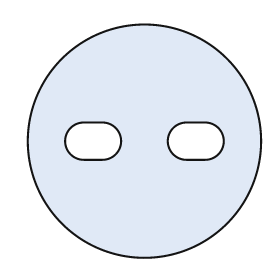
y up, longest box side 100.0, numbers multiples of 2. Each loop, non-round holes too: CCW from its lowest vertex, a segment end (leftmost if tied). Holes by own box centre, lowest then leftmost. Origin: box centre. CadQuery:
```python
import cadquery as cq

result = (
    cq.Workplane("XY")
    .moveTo(0.0, 0.0)
    .circle(50.0)
    .moveTo(-26.0, -8.0)
    .lineTo(-18.0, -8.0)
    .threePointArc((-10.0, 0.0), (-18.0, 8.0))
    .lineTo(-26.0, 8.0)
    .threePointArc((-34.0, 0.0), (-26.0, -8.0))
    .close()
    .moveTo(18.0, -8.0)
    .lineTo(26.0, -8.0)
    .threePointArc((34.0, 0.0), (26.0, 8.0))
    .lineTo(18.0, 8.0)
    .threePointArc((10.0, 0.0), (18.0, -8.0))
    .close()
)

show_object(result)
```